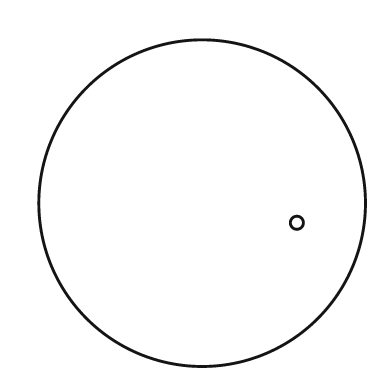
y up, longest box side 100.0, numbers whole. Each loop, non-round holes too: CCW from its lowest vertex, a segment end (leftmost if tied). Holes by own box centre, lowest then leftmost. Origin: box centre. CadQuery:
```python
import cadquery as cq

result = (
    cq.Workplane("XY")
    .moveTo(0.0, 0.0)
    .circle(50.0)
    .moveTo(29.0, -6.0)
    .circle(2.0)
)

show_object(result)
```